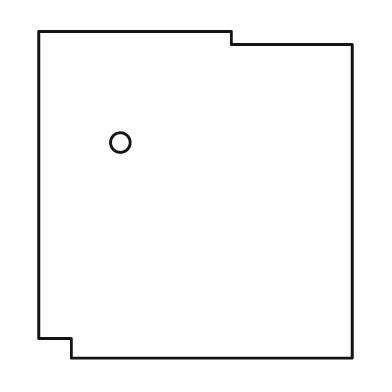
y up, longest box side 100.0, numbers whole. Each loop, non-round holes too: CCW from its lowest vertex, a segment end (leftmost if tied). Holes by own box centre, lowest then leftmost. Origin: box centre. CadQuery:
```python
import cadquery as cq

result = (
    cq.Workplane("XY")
    .moveTo(-38.0, -50.0)
    .lineTo(48.0, -50.0)
    .lineTo(48.0, 46.0)
    .lineTo(11.0, 46.0)
    .lineTo(11.0, 50.0)
    .lineTo(-48.0, 50.0)
    .lineTo(-48.0, -44.0)
    .lineTo(-38.0, -44.0)
    .close()
    .moveTo(-23.0, 16.0)
    .circle(3.0)
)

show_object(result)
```